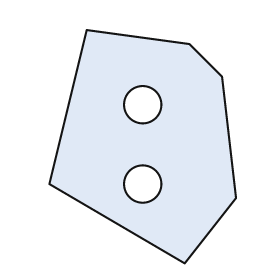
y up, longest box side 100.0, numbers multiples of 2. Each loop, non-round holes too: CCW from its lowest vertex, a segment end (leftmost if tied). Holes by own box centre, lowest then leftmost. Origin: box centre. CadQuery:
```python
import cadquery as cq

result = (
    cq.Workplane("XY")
    .moveTo(18.0, -50.0)
    .lineTo(40.0, -22.0)
    .lineTo(34.0, 30.0)
    .lineTo(20.0, 44.0)
    .lineTo(-24.0, 50.0)
    .lineTo(-40.0, -16.0)
    .close()
    .moveTo(0.0, -16.0)
    .circle(8.0)
    .moveTo(0.0, 18.0)
    .circle(8.0)
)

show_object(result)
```